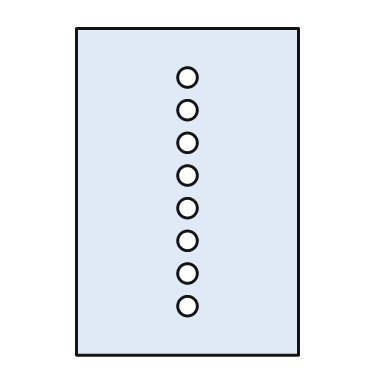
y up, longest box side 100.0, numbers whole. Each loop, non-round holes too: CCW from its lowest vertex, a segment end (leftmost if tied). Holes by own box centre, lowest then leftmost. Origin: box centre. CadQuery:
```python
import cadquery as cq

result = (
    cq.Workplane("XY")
    .moveTo(-34.0, -50.0)
    .lineTo(34.0, -50.0)
    .lineTo(34.0, 50.0)
    .lineTo(-34.0, 50.0)
    .close()
    .moveTo(0.0, -35.0)
    .circle(3.0)
    .moveTo(0.0, -25.0)
    .circle(3.0)
    .moveTo(0.0, -15.0)
    .circle(3.0)
    .moveTo(0.0, -5.0)
    .circle(3.0)
    .moveTo(0.0, 5.0)
    .circle(3.0)
    .moveTo(0.0, 15.0)
    .circle(3.0)
    .moveTo(0.0, 25.0)
    .circle(3.0)
    .moveTo(0.0, 35.0)
    .circle(3.0)
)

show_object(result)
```